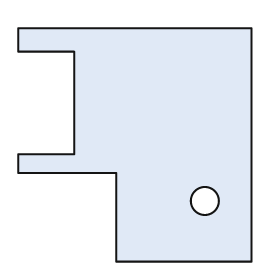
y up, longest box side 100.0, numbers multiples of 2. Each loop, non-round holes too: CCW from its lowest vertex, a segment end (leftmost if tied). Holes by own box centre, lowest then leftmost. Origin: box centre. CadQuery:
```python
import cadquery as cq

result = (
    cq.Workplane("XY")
    .moveTo(-8.0, -50.0)
    .lineTo(50.0, -50.0)
    .lineTo(50.0, 50.0)
    .lineTo(-50.0, 50.0)
    .lineTo(-50.0, 40.0)
    .lineTo(-26.0, 40.0)
    .lineTo(-26.0, -4.0)
    .lineTo(-50.0, -4.0)
    .lineTo(-50.0, -12.0)
    .lineTo(-8.0, -12.0)
    .close()
    .moveTo(30.0, -24.0)
    .circle(6.0)
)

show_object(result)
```